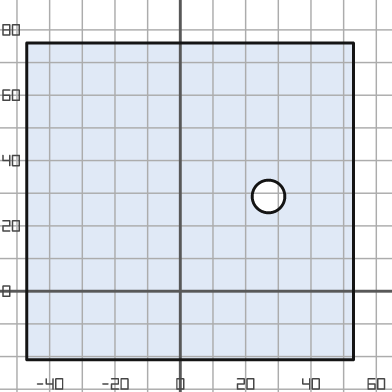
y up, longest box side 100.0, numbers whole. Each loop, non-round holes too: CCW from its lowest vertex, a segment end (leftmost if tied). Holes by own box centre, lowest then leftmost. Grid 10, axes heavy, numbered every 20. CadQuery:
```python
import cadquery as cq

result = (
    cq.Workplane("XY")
    .moveTo(-47.0, -21.0)
    .lineTo(53.0, -21.0)
    .lineTo(53.0, 76.0)
    .lineTo(-47.0, 76.0)
    .close()
    .moveTo(27.0, 29.0)
    .circle(5.0)
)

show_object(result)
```